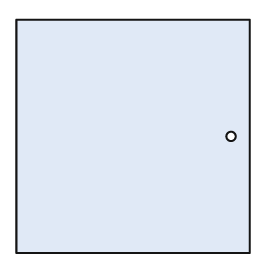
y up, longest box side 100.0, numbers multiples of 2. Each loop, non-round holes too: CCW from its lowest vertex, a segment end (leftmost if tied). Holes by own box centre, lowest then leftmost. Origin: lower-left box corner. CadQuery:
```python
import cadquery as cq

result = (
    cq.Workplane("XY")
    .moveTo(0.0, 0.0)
    .lineTo(100.0, 0.0)
    .lineTo(100.0, 100.0)
    .lineTo(0.0, 100.0)
    .close()
    .moveTo(92.0, 50.0)
    .circle(2.0)
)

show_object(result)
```